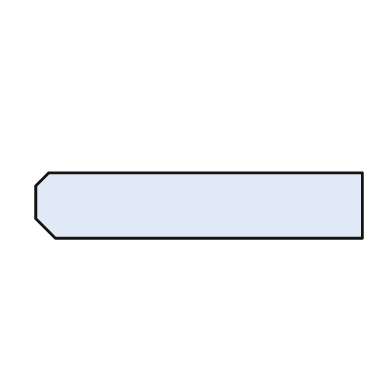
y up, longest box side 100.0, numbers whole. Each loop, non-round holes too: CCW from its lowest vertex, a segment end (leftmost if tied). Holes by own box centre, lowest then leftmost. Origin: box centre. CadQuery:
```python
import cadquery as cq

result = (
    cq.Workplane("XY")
    .moveTo(-44.0, -10.0)
    .lineTo(50.0, -10.0)
    .lineTo(50.0, 10.0)
    .lineTo(-46.0, 10.0)
    .lineTo(-50.0, 6.0)
    .lineTo(-50.0, -4.0)
    .close()
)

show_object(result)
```